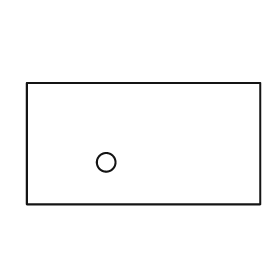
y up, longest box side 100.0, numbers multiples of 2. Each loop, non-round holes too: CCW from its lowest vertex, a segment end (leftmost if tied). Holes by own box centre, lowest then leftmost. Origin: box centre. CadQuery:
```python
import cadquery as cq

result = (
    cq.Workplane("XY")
    .moveTo(-50.0, -26.0)
    .lineTo(50.0, -26.0)
    .lineTo(50.0, 26.0)
    .lineTo(-50.0, 26.0)
    .close()
    .moveTo(-16.0, -8.0)
    .circle(4.0)
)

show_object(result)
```